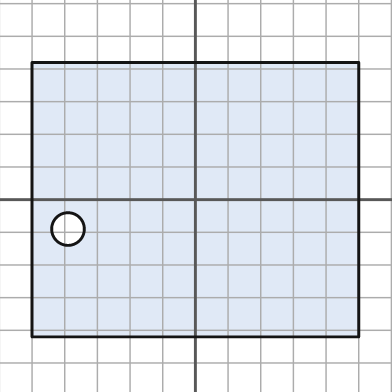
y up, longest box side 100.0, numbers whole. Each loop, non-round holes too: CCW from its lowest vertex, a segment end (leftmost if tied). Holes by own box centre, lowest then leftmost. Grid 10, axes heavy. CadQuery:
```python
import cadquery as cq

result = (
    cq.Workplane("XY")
    .moveTo(-50.0, -42.0)
    .lineTo(50.0, -42.0)
    .lineTo(50.0, 42.0)
    .lineTo(-50.0, 42.0)
    .close()
    .moveTo(-39.0, -9.0)
    .circle(5.0)
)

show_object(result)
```